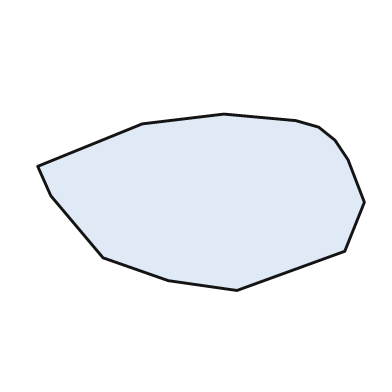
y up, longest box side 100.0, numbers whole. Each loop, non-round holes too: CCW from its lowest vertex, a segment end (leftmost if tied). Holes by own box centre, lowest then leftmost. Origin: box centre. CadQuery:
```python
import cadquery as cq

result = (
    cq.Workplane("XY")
    .moveTo(11.0, -27.0)
    .lineTo(44.0, -15.0)
    .lineTo(50.0, 0.0)
    .lineTo(45.0, 13.0)
    .lineTo(41.0, 19.0)
    .lineTo(36.0, 23.0)
    .lineTo(29.0, 25.0)
    .lineTo(7.0, 27.0)
    .lineTo(-18.0, 24.0)
    .lineTo(-50.0, 11.0)
    .lineTo(-46.0, 2.0)
    .lineTo(-30.0, -17.0)
    .lineTo(-10.0, -24.0)
    .close()
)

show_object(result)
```